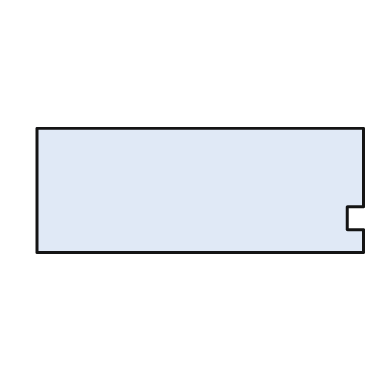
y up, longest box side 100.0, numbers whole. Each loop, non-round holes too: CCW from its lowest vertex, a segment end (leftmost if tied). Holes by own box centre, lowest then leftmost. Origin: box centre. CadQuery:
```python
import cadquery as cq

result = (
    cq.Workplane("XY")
    .moveTo(-50.0, -19.0)
    .lineTo(50.0, -19.0)
    .lineTo(50.0, -12.0)
    .lineTo(45.0, -12.0)
    .lineTo(45.0, -5.0)
    .lineTo(50.0, -5.0)
    .lineTo(50.0, 19.0)
    .lineTo(-50.0, 19.0)
    .close()
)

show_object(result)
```